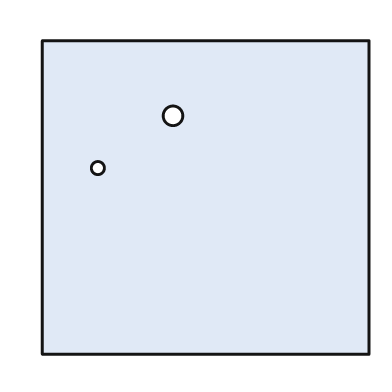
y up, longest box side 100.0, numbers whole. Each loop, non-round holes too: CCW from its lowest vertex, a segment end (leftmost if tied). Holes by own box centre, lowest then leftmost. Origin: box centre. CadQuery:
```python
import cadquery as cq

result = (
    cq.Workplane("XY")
    .moveTo(-50.0, -48.0)
    .lineTo(50.0, -48.0)
    .lineTo(50.0, 48.0)
    .lineTo(-50.0, 48.0)
    .close()
    .moveTo(-33.0, 9.0)
    .circle(2.0)
    .moveTo(-10.0, 25.0)
    .circle(3.0)
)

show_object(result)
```